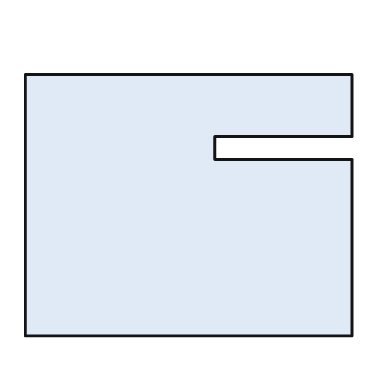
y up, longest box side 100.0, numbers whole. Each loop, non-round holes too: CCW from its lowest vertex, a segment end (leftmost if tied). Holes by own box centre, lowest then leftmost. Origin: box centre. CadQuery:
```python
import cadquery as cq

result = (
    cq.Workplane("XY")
    .moveTo(-50.0, -40.0)
    .lineTo(50.0, -40.0)
    .lineTo(50.0, 14.0)
    .lineTo(8.0, 14.0)
    .lineTo(8.0, 21.0)
    .lineTo(50.0, 21.0)
    .lineTo(50.0, 40.0)
    .lineTo(-50.0, 40.0)
    .close()
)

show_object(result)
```